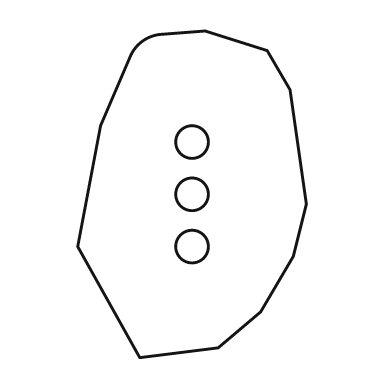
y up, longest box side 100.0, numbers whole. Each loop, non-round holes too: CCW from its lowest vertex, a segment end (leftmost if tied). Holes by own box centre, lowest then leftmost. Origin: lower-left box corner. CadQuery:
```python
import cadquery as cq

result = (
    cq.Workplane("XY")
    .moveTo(19.0, 0.0)
    .lineTo(43.0, 3.0)
    .lineTo(56.0, 14.0)
    .lineTo(66.0, 31.0)
    .lineTo(70.0, 47.0)
    .lineTo(65.0, 82.0)
    .lineTo(58.0, 94.0)
    .lineTo(39.0, 100.0)
    .lineTo(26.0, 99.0)
    .threePointArc((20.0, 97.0), (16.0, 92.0))
    .lineTo(7.0, 71.0)
    .lineTo(0.0, 34.0)
    .close()
    .moveTo(35.0, 34.0)
    .circle(5.0)
    .moveTo(35.0, 50.0)
    .circle(5.0)
    .moveTo(35.0, 66.0)
    .circle(5.0)
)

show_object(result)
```